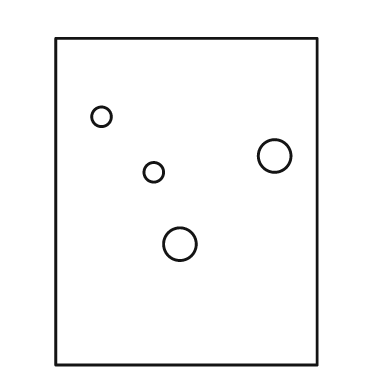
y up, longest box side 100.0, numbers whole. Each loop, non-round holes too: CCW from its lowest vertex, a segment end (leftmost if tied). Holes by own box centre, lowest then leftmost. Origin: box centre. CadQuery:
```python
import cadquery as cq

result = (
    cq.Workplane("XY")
    .moveTo(-40.0, -50.0)
    .lineTo(40.0, -50.0)
    .lineTo(40.0, 50.0)
    .lineTo(-40.0, 50.0)
    .close()
    .moveTo(-2.0, -13.0)
    .circle(5.0)
    .moveTo(-10.0, 9.0)
    .circle(3.0)
    .moveTo(27.0, 14.0)
    .circle(5.0)
    .moveTo(-26.0, 26.0)
    .circle(3.0)
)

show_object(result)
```